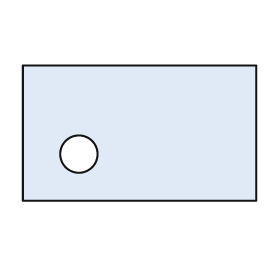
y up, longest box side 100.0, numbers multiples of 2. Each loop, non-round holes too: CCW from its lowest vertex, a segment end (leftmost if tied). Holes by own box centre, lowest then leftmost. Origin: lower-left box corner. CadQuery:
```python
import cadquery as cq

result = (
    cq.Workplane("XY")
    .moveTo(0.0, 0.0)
    .lineTo(100.0, 0.0)
    .lineTo(100.0, 58.0)
    .lineTo(0.0, 58.0)
    .close()
    .moveTo(24.0, 20.0)
    .circle(8.0)
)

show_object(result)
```